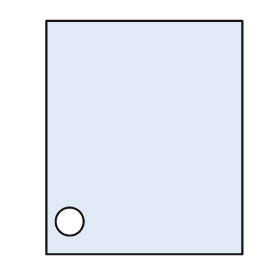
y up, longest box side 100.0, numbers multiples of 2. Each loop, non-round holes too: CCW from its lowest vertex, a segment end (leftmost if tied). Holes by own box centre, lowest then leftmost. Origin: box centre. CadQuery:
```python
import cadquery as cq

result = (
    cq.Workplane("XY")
    .moveTo(-42.0, -50.0)
    .lineTo(42.0, -50.0)
    .lineTo(42.0, 50.0)
    .lineTo(-42.0, 50.0)
    .close()
    .moveTo(-32.0, -36.0)
    .circle(6.0)
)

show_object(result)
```